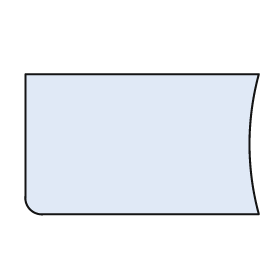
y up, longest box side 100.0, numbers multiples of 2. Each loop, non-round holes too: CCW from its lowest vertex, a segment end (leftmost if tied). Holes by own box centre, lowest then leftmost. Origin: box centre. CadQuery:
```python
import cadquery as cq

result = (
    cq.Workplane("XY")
    .moveTo(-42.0, -30.0)
    .lineTo(50.0, -30.0)
    .threePointArc((46.0, 0.0), (50.0, 30.0))
    .lineTo(-50.0, 30.0)
    .lineTo(-50.0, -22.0)
    .threePointArc((-48.0, -28.0), (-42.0, -30.0))
    .close()
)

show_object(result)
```